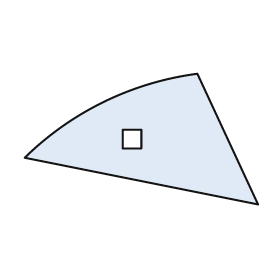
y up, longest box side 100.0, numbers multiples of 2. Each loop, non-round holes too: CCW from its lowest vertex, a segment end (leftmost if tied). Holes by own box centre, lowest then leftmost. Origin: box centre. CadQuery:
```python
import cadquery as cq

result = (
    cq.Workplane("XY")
    .moveTo(50.0, -28.0)
    .lineTo(24.0, 28.0)
    .threePointArc((-16.0, 16.0), (-50.0, -8.0))
    .close()
    .moveTo(-8.0, -4.0)
    .lineTo(0.0, -4.0)
    .lineTo(0.0, 4.0)
    .lineTo(-8.0, 4.0)
    .close()
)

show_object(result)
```